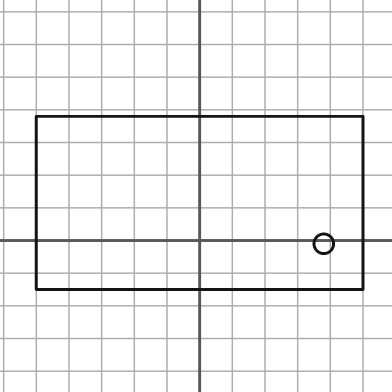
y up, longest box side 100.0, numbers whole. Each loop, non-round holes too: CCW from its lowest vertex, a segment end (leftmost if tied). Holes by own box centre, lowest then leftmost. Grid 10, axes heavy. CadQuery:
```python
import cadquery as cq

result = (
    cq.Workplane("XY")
    .moveTo(-50.0, -15.0)
    .lineTo(50.0, -15.0)
    .lineTo(50.0, 38.0)
    .lineTo(-50.0, 38.0)
    .close()
    .moveTo(38.0, -1.0)
    .circle(3.0)
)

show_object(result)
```